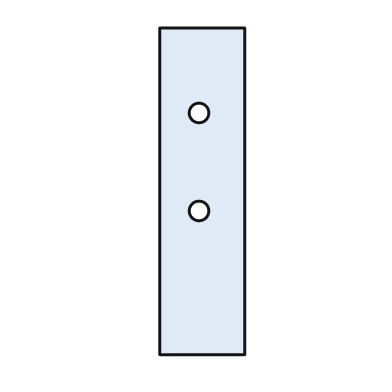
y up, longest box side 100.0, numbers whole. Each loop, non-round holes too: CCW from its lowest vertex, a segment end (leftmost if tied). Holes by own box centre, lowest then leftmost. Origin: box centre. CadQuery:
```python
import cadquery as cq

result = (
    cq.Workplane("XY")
    .moveTo(-13.0, -50.0)
    .lineTo(13.0, -50.0)
    .lineTo(13.0, 50.0)
    .lineTo(-13.0, 50.0)
    .close()
    .moveTo(-1.0, -6.0)
    .circle(3.0)
    .moveTo(-1.0, 24.0)
    .circle(3.0)
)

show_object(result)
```